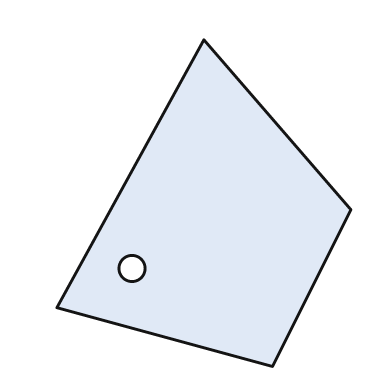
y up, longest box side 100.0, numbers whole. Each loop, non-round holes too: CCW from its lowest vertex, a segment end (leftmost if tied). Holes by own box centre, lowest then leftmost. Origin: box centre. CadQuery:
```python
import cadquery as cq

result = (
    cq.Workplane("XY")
    .moveTo(21.0, -50.0)
    .lineTo(45.0, -2.0)
    .lineTo(0.0, 50.0)
    .lineTo(-45.0, -32.0)
    .close()
    .moveTo(-22.0, -20.0)
    .circle(4.0)
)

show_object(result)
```